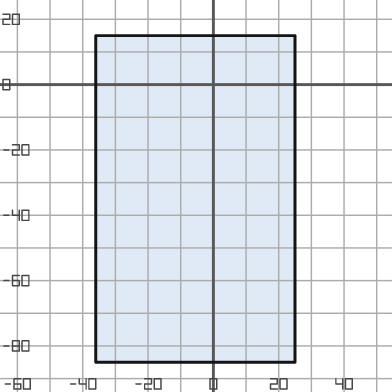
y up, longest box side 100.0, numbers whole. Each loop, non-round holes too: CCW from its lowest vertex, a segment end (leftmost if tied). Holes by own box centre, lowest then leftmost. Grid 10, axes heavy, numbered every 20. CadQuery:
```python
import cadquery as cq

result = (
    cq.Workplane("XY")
    .moveTo(-36.0, -85.0)
    .lineTo(25.0, -85.0)
    .lineTo(25.0, 15.0)
    .lineTo(-36.0, 15.0)
    .close()
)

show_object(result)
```